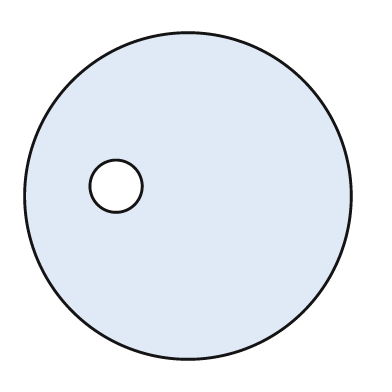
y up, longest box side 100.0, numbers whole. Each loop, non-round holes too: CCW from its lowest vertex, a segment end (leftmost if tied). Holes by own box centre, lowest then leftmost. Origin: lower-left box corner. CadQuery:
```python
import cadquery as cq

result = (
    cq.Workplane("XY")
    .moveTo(50.0, 50.0)
    .circle(50.0)
    .moveTo(28.0, 53.0)
    .circle(8.0)
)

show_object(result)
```